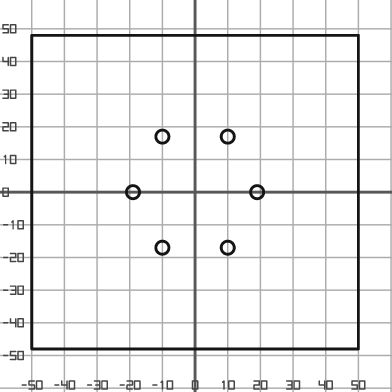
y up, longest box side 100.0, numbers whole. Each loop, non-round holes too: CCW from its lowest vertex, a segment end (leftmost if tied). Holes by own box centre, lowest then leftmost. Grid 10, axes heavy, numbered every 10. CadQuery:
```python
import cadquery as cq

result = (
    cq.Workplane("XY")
    .moveTo(-50.0, -48.0)
    .lineTo(50.0, -48.0)
    .lineTo(50.0, 48.0)
    .lineTo(-50.0, 48.0)
    .close()
    .moveTo(-10.0, -17.0)
    .circle(2.0)
    .moveTo(10.0, -17.0)
    .circle(2.0)
    .moveTo(-19.0, 0.0)
    .circle(2.0)
    .moveTo(19.0, 0.0)
    .circle(2.0)
    .moveTo(-10.0, 17.0)
    .circle(2.0)
    .moveTo(10.0, 17.0)
    .circle(2.0)
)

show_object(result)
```